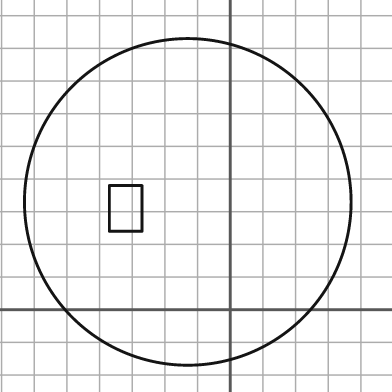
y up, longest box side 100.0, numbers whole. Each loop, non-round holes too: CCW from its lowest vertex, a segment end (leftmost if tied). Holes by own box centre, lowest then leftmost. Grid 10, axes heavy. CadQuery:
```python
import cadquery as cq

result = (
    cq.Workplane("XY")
    .moveTo(-13.0, 33.0)
    .circle(50.0)
    .moveTo(-37.0, 24.0)
    .lineTo(-27.0, 24.0)
    .lineTo(-27.0, 38.0)
    .lineTo(-37.0, 38.0)
    .close()
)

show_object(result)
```